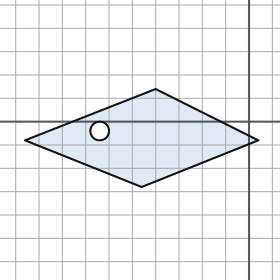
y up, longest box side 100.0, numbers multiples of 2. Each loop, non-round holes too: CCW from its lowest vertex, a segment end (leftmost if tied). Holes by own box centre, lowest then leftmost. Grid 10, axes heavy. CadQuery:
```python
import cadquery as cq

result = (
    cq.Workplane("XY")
    .moveTo(-46.0, -28.0)
    .lineTo(4.0, -8.0)
    .lineTo(-40.0, 14.0)
    .lineTo(-96.0, -8.0)
    .close()
    .moveTo(-64.0, -4.0)
    .circle(4.0)
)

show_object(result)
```